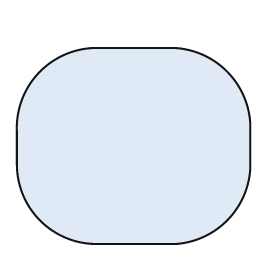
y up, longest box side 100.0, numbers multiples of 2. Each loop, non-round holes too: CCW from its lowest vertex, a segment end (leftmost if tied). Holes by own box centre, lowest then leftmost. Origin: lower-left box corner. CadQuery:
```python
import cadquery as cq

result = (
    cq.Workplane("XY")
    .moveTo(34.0, 0.0)
    .lineTo(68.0, 0.0)
    .threePointArc((90.0, 10.0), (100.0, 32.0))
    .lineTo(100.0, 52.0)
    .threePointArc((90.0, 74.0), (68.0, 84.0))
    .lineTo(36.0, 84.0)
    .threePointArc((10.0, 74.0), (0.0, 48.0))
    .lineTo(0.0, 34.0)
    .threePointArc((10.0, 10.0), (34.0, 0.0))
    .close()
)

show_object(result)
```